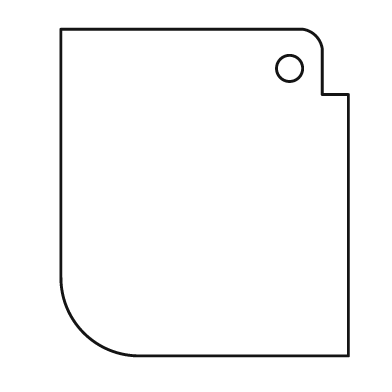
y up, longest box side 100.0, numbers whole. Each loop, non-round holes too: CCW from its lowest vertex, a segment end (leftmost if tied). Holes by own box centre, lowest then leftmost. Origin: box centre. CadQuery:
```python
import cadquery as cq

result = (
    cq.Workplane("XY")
    .moveTo(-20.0, -50.0)
    .lineTo(44.0, -50.0)
    .lineTo(44.0, 30.0)
    .lineTo(36.0, 30.0)
    .lineTo(36.0, 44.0)
    .threePointArc((34.0, 48.0), (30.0, 50.0))
    .lineTo(-44.0, 50.0)
    .lineTo(-44.0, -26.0)
    .threePointArc((-37.0, -43.0), (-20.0, -50.0))
    .close()
    .moveTo(26.0, 38.0)
    .circle(4.0)
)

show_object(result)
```